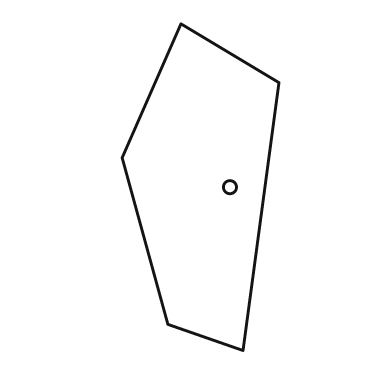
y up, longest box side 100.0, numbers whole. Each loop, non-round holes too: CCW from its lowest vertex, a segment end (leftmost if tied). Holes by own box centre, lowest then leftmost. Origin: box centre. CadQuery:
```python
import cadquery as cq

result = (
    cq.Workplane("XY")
    .moveTo(13.0, -50.0)
    .lineTo(24.0, 32.0)
    .lineTo(-6.0, 50.0)
    .lineTo(-24.0, 9.0)
    .lineTo(-10.0, -42.0)
    .close()
    .moveTo(9.0, 0.0)
    .circle(2.0)
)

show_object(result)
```